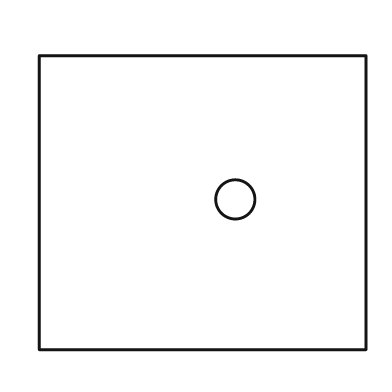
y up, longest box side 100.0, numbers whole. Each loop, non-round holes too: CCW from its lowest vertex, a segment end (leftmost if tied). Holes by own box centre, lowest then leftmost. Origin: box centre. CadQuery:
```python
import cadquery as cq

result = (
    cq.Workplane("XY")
    .moveTo(-50.0, -45.0)
    .lineTo(50.0, -45.0)
    .lineTo(50.0, 45.0)
    .lineTo(-50.0, 45.0)
    .close()
    .moveTo(10.0, 1.0)
    .circle(6.0)
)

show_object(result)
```